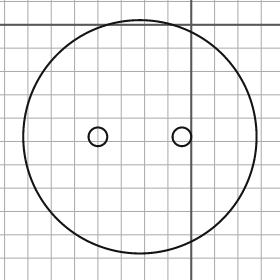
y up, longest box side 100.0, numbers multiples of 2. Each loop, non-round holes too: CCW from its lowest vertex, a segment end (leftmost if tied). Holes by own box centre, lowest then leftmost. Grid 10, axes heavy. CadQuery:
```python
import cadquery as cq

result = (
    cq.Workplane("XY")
    .moveTo(-22.0, -48.0)
    .circle(50.0)
    .moveTo(-40.0, -48.0)
    .circle(4.0)
    .moveTo(-4.0, -48.0)
    .circle(4.0)
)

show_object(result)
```